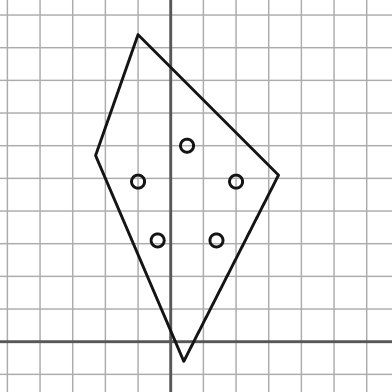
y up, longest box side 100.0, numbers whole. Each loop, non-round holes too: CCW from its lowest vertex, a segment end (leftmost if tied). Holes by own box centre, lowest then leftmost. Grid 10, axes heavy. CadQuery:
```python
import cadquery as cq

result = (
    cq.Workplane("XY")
    .moveTo(4.0, -6.0)
    .lineTo(33.0, 51.0)
    .lineTo(-10.0, 94.0)
    .lineTo(-23.0, 57.0)
    .close()
    .moveTo(-4.0, 31.0)
    .circle(2.0)
    .moveTo(14.0, 31.0)
    .circle(2.0)
    .moveTo(-10.0, 49.0)
    .circle(2.0)
    .moveTo(20.0, 49.0)
    .circle(2.0)
    .moveTo(5.0, 60.0)
    .circle(2.0)
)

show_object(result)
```